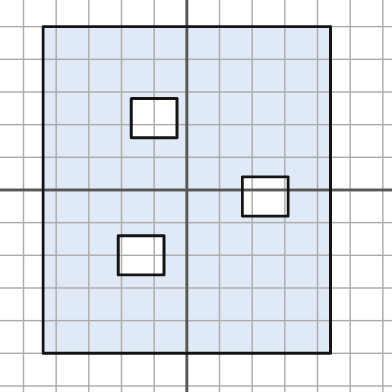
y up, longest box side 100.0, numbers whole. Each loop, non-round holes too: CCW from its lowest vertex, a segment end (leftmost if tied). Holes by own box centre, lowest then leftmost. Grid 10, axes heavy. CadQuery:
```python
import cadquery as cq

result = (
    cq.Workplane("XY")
    .moveTo(-44.0, -50.0)
    .lineTo(44.0, -50.0)
    .lineTo(44.0, 50.0)
    .lineTo(-44.0, 50.0)
    .close()
    .moveTo(-21.0, -26.0)
    .lineTo(-7.0, -26.0)
    .lineTo(-7.0, -14.0)
    .lineTo(-21.0, -14.0)
    .close()
    .moveTo(17.0, -8.0)
    .lineTo(31.0, -8.0)
    .lineTo(31.0, 4.0)
    .lineTo(17.0, 4.0)
    .close()
    .moveTo(-17.0, 16.0)
    .lineTo(-3.0, 16.0)
    .lineTo(-3.0, 28.0)
    .lineTo(-17.0, 28.0)
    .close()
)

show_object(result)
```